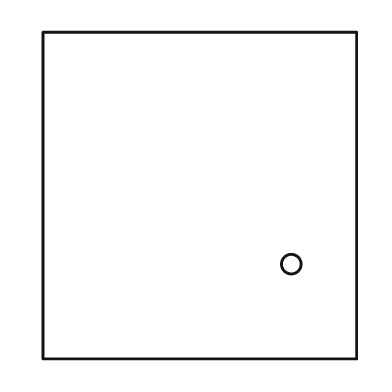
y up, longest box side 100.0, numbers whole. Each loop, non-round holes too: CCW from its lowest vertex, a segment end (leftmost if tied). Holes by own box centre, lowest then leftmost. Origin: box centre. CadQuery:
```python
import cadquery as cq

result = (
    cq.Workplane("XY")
    .moveTo(-48.0, -50.0)
    .lineTo(48.0, -50.0)
    .lineTo(48.0, 50.0)
    .lineTo(-48.0, 50.0)
    .close()
    .moveTo(28.0, -21.0)
    .circle(3.0)
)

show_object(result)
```